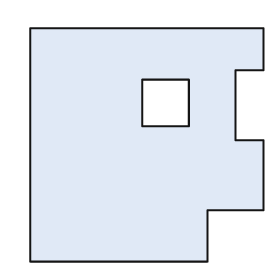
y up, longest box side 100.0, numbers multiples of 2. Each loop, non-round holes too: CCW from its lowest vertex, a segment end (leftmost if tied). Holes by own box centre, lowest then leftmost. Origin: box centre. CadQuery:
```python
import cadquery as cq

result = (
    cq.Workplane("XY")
    .moveTo(-50.0, -50.0)
    .lineTo(26.0, -50.0)
    .lineTo(26.0, -28.0)
    .lineTo(50.0, -28.0)
    .lineTo(50.0, 2.0)
    .lineTo(38.0, 2.0)
    .lineTo(38.0, 32.0)
    .lineTo(50.0, 32.0)
    .lineTo(50.0, 50.0)
    .lineTo(-50.0, 50.0)
    .close()
    .moveTo(-2.0, 8.0)
    .lineTo(18.0, 8.0)
    .lineTo(18.0, 28.0)
    .lineTo(-2.0, 28.0)
    .close()
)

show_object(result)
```